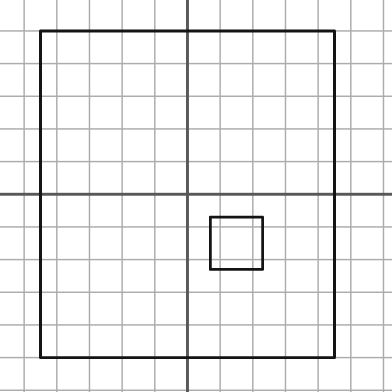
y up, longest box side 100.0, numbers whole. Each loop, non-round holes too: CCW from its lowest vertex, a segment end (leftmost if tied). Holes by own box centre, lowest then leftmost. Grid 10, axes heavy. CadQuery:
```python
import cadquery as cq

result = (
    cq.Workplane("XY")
    .moveTo(-45.0, -50.0)
    .lineTo(45.0, -50.0)
    .lineTo(45.0, 50.0)
    .lineTo(-45.0, 50.0)
    .close()
    .moveTo(7.0, -23.0)
    .lineTo(23.0, -23.0)
    .lineTo(23.0, -7.0)
    .lineTo(7.0, -7.0)
    .close()
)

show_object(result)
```